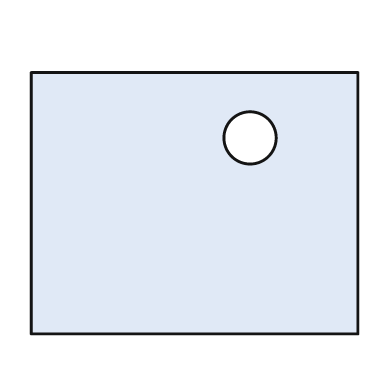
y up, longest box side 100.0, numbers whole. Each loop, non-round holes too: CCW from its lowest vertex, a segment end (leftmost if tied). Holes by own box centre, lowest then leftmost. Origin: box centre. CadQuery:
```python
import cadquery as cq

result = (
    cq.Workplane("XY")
    .moveTo(-50.0, -40.0)
    .lineTo(50.0, -40.0)
    .lineTo(50.0, 40.0)
    .lineTo(-50.0, 40.0)
    .close()
    .moveTo(17.0, 20.0)
    .circle(8.0)
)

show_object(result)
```